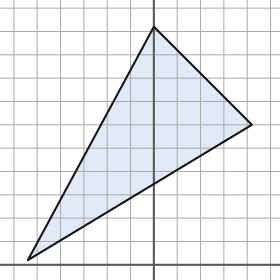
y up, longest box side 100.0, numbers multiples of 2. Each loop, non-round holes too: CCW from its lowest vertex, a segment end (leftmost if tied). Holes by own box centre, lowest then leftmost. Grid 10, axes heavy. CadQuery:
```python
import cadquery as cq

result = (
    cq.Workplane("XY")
    .moveTo(-54.0, 2.0)
    .lineTo(42.0, 60.0)
    .lineTo(0.0, 102.0)
    .close()
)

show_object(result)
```